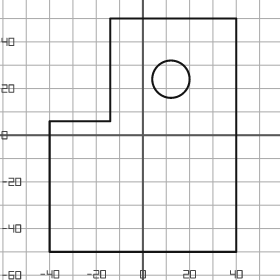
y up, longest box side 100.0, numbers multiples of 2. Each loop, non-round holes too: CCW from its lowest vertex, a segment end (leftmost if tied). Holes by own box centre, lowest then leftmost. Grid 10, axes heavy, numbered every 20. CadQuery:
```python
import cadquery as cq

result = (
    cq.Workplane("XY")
    .moveTo(-40.0, -50.0)
    .lineTo(40.0, -50.0)
    .lineTo(40.0, 50.0)
    .lineTo(-14.0, 50.0)
    .lineTo(-14.0, 6.0)
    .lineTo(-40.0, 6.0)
    .close()
    .moveTo(12.0, 24.0)
    .circle(8.0)
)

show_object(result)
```